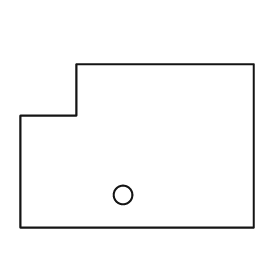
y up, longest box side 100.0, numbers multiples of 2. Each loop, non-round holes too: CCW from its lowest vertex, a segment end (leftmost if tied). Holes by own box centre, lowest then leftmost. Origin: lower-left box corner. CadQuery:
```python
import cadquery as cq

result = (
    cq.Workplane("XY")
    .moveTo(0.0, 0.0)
    .lineTo(100.0, 0.0)
    .lineTo(100.0, 70.0)
    .lineTo(24.0, 70.0)
    .lineTo(24.0, 48.0)
    .lineTo(0.0, 48.0)
    .close()
    .moveTo(44.0, 14.0)
    .circle(4.0)
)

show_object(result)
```